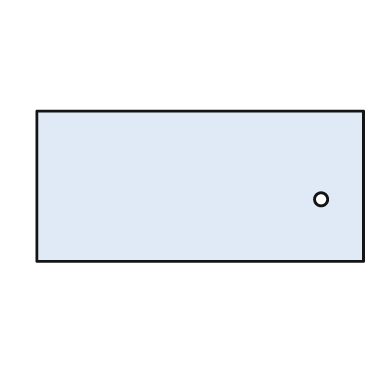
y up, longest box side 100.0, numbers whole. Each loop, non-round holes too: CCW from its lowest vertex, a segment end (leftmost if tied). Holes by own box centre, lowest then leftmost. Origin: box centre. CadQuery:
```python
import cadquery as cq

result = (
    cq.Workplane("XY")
    .moveTo(-50.0, -23.0)
    .lineTo(50.0, -23.0)
    .lineTo(50.0, 23.0)
    .lineTo(-50.0, 23.0)
    .close()
    .moveTo(37.0, -4.0)
    .circle(2.0)
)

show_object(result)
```